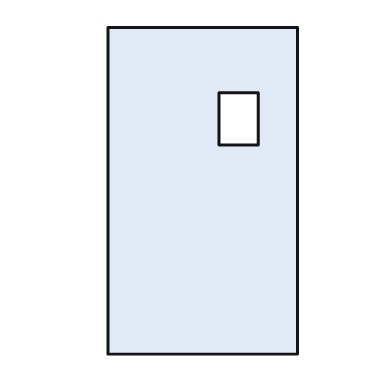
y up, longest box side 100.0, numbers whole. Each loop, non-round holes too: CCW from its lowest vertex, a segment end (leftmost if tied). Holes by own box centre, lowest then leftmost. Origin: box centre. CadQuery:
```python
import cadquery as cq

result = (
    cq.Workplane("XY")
    .moveTo(-29.0, -50.0)
    .lineTo(29.0, -50.0)
    .lineTo(29.0, 50.0)
    .lineTo(-29.0, 50.0)
    .close()
    .moveTo(5.0, 14.0)
    .lineTo(17.0, 14.0)
    .lineTo(17.0, 30.0)
    .lineTo(5.0, 30.0)
    .close()
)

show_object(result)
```